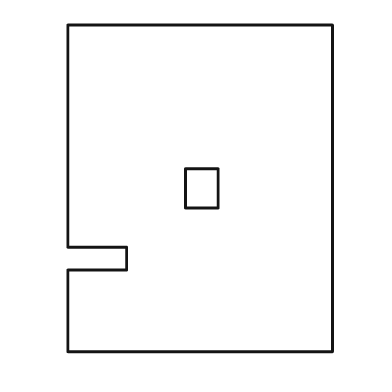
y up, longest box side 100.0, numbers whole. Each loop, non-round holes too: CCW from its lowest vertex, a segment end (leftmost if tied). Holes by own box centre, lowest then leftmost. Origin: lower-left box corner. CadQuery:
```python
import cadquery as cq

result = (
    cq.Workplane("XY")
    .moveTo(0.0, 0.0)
    .lineTo(81.0, 0.0)
    .lineTo(81.0, 100.0)
    .lineTo(0.0, 100.0)
    .lineTo(0.0, 32.0)
    .lineTo(18.0, 32.0)
    .lineTo(18.0, 25.0)
    .lineTo(0.0, 25.0)
    .close()
    .moveTo(36.0, 44.0)
    .lineTo(46.0, 44.0)
    .lineTo(46.0, 56.0)
    .lineTo(36.0, 56.0)
    .close()
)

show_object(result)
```